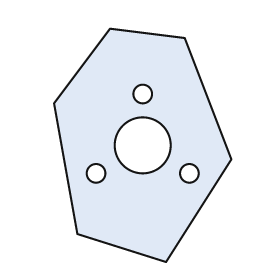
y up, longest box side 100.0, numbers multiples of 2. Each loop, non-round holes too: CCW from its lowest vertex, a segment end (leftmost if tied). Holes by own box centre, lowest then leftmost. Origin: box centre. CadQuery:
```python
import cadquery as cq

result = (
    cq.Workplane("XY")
    .moveTo(10.0, -50.0)
    .lineTo(38.0, -6.0)
    .lineTo(18.0, 46.0)
    .lineTo(-14.0, 50.0)
    .lineTo(-38.0, 18.0)
    .lineTo(-28.0, -38.0)
    .close()
    .moveTo(-20.0, -12.0)
    .circle(4.0)
    .moveTo(20.0, -12.0)
    .circle(4.0)
    .moveTo(0.0, 0.0)
    .circle(12.0)
    .moveTo(0.0, 22.0)
    .circle(4.0)
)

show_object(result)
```